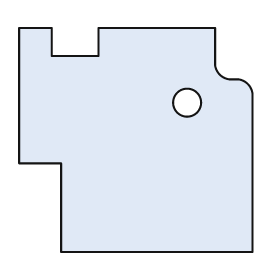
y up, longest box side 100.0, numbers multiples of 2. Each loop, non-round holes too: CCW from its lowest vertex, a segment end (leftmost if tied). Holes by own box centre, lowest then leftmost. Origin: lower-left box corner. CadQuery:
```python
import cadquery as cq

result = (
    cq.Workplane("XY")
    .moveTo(18.0, 0.0)
    .lineTo(100.0, 0.0)
    .lineTo(100.0, 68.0)
    .threePointArc((98.0, 72.0), (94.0, 74.0))
    .lineTo(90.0, 74.0)
    .threePointArc((86.0, 76.0), (84.0, 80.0))
    .lineTo(84.0, 96.0)
    .lineTo(34.0, 96.0)
    .lineTo(34.0, 84.0)
    .lineTo(14.0, 84.0)
    .lineTo(14.0, 96.0)
    .lineTo(0.0, 96.0)
    .lineTo(0.0, 38.0)
    .lineTo(18.0, 38.0)
    .close()
    .moveTo(72.0, 64.0)
    .circle(6.0)
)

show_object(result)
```